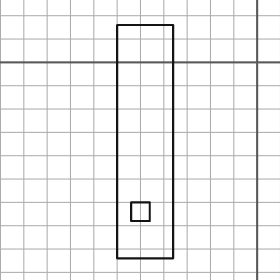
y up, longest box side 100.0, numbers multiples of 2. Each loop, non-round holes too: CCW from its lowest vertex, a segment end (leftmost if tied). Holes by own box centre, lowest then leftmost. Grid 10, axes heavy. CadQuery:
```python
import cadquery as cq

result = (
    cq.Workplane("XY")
    .moveTo(-60.0, -84.0)
    .lineTo(-36.0, -84.0)
    .lineTo(-36.0, 16.0)
    .lineTo(-60.0, 16.0)
    .close()
    .moveTo(-54.0, -68.0)
    .lineTo(-46.0, -68.0)
    .lineTo(-46.0, -60.0)
    .lineTo(-54.0, -60.0)
    .close()
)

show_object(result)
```